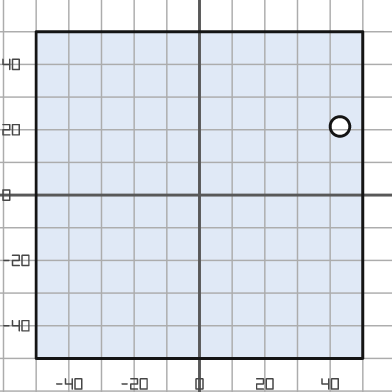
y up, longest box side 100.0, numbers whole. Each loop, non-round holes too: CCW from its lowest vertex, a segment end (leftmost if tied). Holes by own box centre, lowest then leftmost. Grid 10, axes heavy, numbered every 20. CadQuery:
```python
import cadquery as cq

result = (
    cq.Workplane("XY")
    .moveTo(-50.0, -50.0)
    .lineTo(50.0, -50.0)
    .lineTo(50.0, 50.0)
    .lineTo(-50.0, 50.0)
    .close()
    .moveTo(43.0, 21.0)
    .circle(3.0)
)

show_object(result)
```